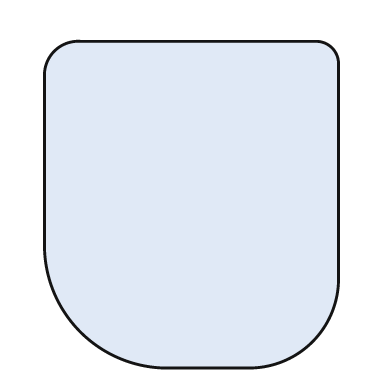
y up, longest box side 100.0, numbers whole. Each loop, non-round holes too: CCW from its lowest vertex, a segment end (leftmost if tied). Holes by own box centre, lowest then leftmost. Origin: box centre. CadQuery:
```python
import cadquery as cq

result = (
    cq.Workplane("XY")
    .moveTo(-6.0, -50.0)
    .lineTo(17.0, -50.0)
    .threePointArc((37.0, -42.0), (45.0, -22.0))
    .lineTo(45.0, 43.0)
    .threePointArc((43.0, 48.0), (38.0, 50.0))
    .lineTo(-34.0, 50.0)
    .threePointArc((-42.0, 47.0), (-45.0, 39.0))
    .lineTo(-45.0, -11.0)
    .threePointArc((-34.0, -39.0), (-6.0, -50.0))
    .close()
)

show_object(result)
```